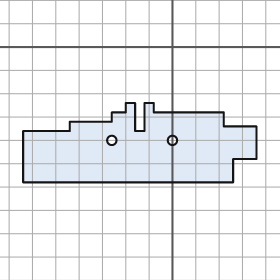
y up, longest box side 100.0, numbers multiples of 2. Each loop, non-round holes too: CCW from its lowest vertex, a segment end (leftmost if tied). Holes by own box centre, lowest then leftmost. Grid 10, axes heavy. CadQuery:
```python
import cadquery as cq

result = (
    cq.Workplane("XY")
    .moveTo(-64.0, -58.0)
    .lineTo(26.0, -58.0)
    .lineTo(26.0, -48.0)
    .lineTo(36.0, -48.0)
    .lineTo(36.0, -34.0)
    .lineTo(22.0, -34.0)
    .lineTo(22.0, -28.0)
    .lineTo(-8.0, -28.0)
    .lineTo(-8.0, -24.0)
    .lineTo(-12.0, -24.0)
    .lineTo(-12.0, -36.0)
    .lineTo(-16.0, -36.0)
    .lineTo(-16.0, -24.0)
    .lineTo(-20.0, -24.0)
    .lineTo(-20.0, -28.0)
    .lineTo(-26.0, -28.0)
    .lineTo(-26.0, -32.0)
    .lineTo(-44.0, -32.0)
    .lineTo(-44.0, -36.0)
    .lineTo(-64.0, -36.0)
    .close()
    .moveTo(-26.0, -40.0)
    .circle(2.0)
    .moveTo(0.0, -40.0)
    .circle(2.0)
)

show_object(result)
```